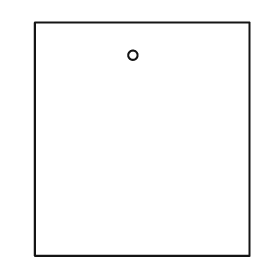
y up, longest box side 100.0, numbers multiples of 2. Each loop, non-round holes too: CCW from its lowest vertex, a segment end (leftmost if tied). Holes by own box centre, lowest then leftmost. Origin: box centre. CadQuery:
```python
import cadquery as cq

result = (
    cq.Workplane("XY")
    .moveTo(-46.0, -50.0)
    .lineTo(46.0, -50.0)
    .lineTo(46.0, 50.0)
    .lineTo(-46.0, 50.0)
    .close()
    .moveTo(-4.0, 36.0)
    .circle(2.0)
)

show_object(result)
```